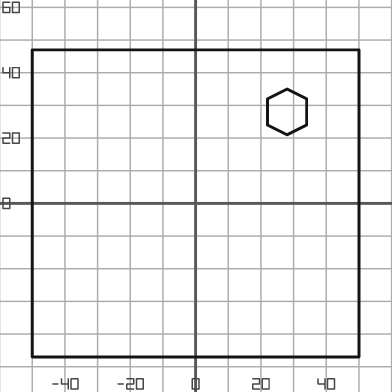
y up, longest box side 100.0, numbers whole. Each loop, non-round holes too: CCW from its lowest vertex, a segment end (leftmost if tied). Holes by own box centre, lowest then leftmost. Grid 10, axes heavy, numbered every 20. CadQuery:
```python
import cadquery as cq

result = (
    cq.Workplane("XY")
    .moveTo(-50.0, -47.0)
    .lineTo(50.0, -47.0)
    .lineTo(50.0, 47.0)
    .lineTo(-50.0, 47.0)
    .close()
    .moveTo(28.0, 21.0)
    .lineTo(34.0, 24.0)
    .lineTo(34.0, 32.0)
    .lineTo(28.0, 35.0)
    .lineTo(22.0, 32.0)
    .lineTo(22.0, 24.0)
    .close()
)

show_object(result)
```